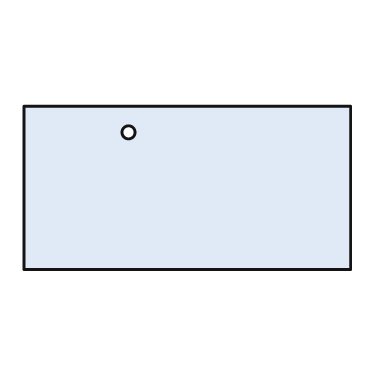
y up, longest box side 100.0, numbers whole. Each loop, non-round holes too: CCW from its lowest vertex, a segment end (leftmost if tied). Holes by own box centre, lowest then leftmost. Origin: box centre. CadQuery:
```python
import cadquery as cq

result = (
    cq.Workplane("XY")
    .moveTo(-50.0, -25.0)
    .lineTo(50.0, -25.0)
    .lineTo(50.0, 25.0)
    .lineTo(-50.0, 25.0)
    .close()
    .moveTo(-18.0, 17.0)
    .circle(2.0)
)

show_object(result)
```